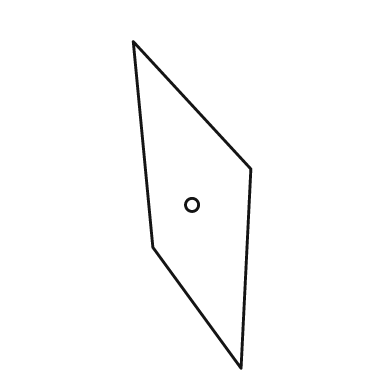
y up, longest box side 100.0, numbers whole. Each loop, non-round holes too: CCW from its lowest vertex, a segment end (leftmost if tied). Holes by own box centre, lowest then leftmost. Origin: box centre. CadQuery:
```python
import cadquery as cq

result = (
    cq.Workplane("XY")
    .moveTo(15.0, -50.0)
    .lineTo(18.0, 11.0)
    .lineTo(-18.0, 50.0)
    .lineTo(-12.0, -13.0)
    .close()
    .moveTo(0.0, 0.0)
    .circle(2.0)
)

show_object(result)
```